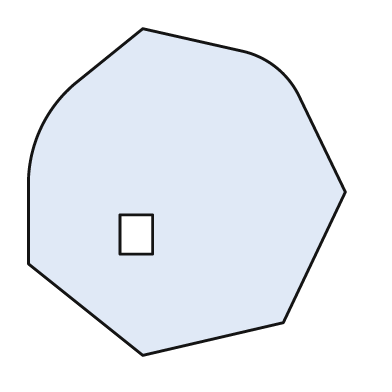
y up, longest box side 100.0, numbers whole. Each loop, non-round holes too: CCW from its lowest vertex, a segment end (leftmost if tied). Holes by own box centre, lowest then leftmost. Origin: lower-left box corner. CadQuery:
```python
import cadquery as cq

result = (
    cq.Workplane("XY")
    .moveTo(35.0, 0.0)
    .lineTo(78.0, 10.0)
    .lineTo(97.0, 50.0)
    .lineTo(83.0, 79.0)
    .threePointArc((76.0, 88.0), (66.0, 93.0))
    .lineTo(35.0, 100.0)
    .lineTo(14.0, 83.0)
    .threePointArc((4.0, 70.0), (0.0, 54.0))
    .lineTo(0.0, 28.0)
    .close()
    .moveTo(28.0, 31.0)
    .lineTo(38.0, 31.0)
    .lineTo(38.0, 43.0)
    .lineTo(28.0, 43.0)
    .close()
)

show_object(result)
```